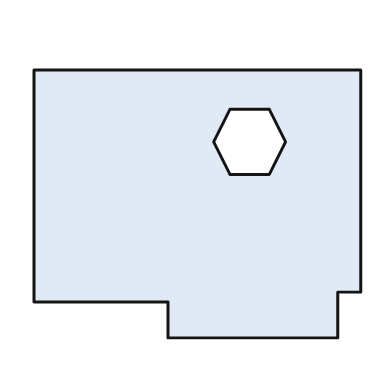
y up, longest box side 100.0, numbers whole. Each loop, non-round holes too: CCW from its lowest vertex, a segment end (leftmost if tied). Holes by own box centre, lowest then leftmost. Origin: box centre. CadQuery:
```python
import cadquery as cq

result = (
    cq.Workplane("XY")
    .moveTo(-9.0, -41.0)
    .lineTo(43.0, -41.0)
    .lineTo(43.0, -27.0)
    .lineTo(50.0, -27.0)
    .lineTo(50.0, 41.0)
    .lineTo(-50.0, 41.0)
    .lineTo(-50.0, -30.0)
    .lineTo(-9.0, -30.0)
    .close()
    .moveTo(10.0, 9.0)
    .lineTo(22.0, 9.0)
    .lineTo(27.0, 19.0)
    .lineTo(22.0, 29.0)
    .lineTo(10.0, 29.0)
    .lineTo(5.0, 19.0)
    .close()
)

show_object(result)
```